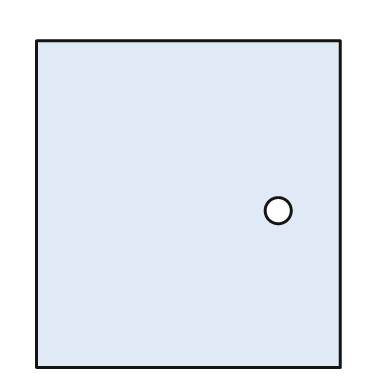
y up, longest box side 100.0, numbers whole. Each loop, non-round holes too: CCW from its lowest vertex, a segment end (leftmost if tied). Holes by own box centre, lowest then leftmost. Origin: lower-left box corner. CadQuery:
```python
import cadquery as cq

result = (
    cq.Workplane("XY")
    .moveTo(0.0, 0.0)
    .lineTo(93.0, 0.0)
    .lineTo(93.0, 100.0)
    .lineTo(0.0, 100.0)
    .close()
    .moveTo(74.0, 48.0)
    .circle(4.0)
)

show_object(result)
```